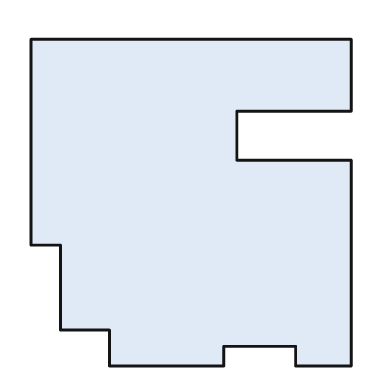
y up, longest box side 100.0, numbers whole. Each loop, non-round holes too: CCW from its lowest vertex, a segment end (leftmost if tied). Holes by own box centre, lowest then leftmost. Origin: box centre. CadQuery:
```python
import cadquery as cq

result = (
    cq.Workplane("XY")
    .moveTo(-25.0, -50.0)
    .lineTo(10.0, -50.0)
    .lineTo(10.0, -44.0)
    .lineTo(32.0, -44.0)
    .lineTo(32.0, -50.0)
    .lineTo(49.0, -50.0)
    .lineTo(49.0, 13.0)
    .lineTo(14.0, 13.0)
    .lineTo(14.0, 28.0)
    .lineTo(49.0, 28.0)
    .lineTo(49.0, 50.0)
    .lineTo(-49.0, 50.0)
    .lineTo(-49.0, -13.0)
    .lineTo(-40.0, -13.0)
    .lineTo(-40.0, -39.0)
    .lineTo(-25.0, -39.0)
    .close()
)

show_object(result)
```